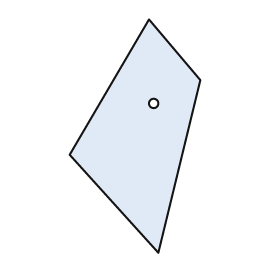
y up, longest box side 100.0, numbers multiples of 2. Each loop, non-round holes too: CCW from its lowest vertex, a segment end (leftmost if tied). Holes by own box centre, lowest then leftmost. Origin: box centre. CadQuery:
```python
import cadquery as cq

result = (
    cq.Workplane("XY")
    .moveTo(10.0, -50.0)
    .lineTo(28.0, 24.0)
    .lineTo(6.0, 50.0)
    .lineTo(-28.0, -8.0)
    .close()
    .moveTo(8.0, 14.0)
    .circle(2.0)
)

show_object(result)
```